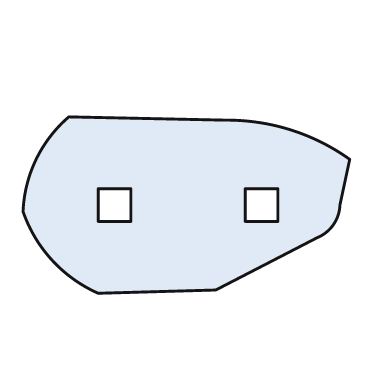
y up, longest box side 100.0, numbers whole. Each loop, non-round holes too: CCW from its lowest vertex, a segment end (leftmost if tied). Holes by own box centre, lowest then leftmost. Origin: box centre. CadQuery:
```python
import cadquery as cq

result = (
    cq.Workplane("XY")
    .moveTo(-27.0, -27.0)
    .lineTo(9.0, -26.0)
    .lineTo(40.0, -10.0)
    .threePointArc((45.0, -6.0), (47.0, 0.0))
    .lineTo(50.0, 14.0)
    .threePointArc((32.0, 23.0), (12.0, 26.0))
    .lineTo(-36.0, 27.0)
    .threePointArc((-46.0, 14.0), (-50.0, -2.0))
    .threePointArc((-41.0, -17.0), (-27.0, -27.0))
    .close()
    .moveTo(-27.0, -5.0)
    .lineTo(-17.0, -5.0)
    .lineTo(-17.0, 5.0)
    .lineTo(-27.0, 5.0)
    .close()
    .moveTo(18.0, -5.0)
    .lineTo(28.0, -5.0)
    .lineTo(28.0, 5.0)
    .lineTo(18.0, 5.0)
    .close()
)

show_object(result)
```